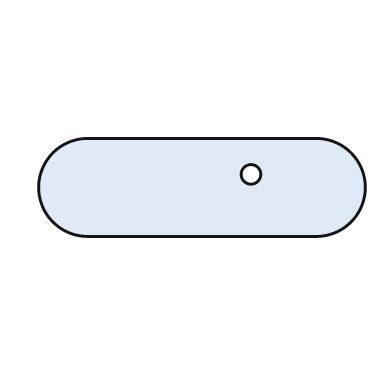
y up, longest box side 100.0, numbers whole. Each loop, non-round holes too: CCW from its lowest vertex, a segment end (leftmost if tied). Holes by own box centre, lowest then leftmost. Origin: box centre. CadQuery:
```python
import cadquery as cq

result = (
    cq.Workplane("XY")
    .moveTo(-35.0, -15.0)
    .lineTo(35.0, -15.0)
    .threePointArc((50.0, 0.0), (35.0, 15.0))
    .lineTo(-35.0, 15.0)
    .threePointArc((-50.0, 0.0), (-35.0, -15.0))
    .close()
    .moveTo(15.0, 4.0)
    .circle(3.0)
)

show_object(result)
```